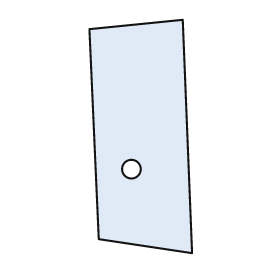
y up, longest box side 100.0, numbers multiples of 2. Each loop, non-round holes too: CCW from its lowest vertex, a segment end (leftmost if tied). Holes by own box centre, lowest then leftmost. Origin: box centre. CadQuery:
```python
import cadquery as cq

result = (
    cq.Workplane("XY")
    .moveTo(22.0, -50.0)
    .lineTo(18.0, 50.0)
    .lineTo(-22.0, 46.0)
    .lineTo(-18.0, -44.0)
    .close()
    .moveTo(-4.0, -14.0)
    .circle(4.0)
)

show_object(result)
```